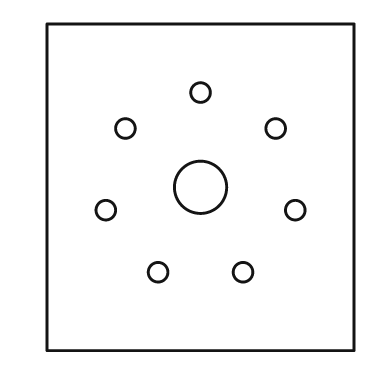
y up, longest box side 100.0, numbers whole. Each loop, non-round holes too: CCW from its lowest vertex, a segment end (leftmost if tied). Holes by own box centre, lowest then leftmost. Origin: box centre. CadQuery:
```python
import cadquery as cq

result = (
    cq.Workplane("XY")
    .moveTo(-47.0, -50.0)
    .lineTo(47.0, -50.0)
    .lineTo(47.0, 50.0)
    .lineTo(-47.0, 50.0)
    .close()
    .moveTo(-13.0, -26.0)
    .circle(3.0)
    .moveTo(13.0, -26.0)
    .circle(3.0)
    .moveTo(-29.0, -7.0)
    .circle(3.0)
    .moveTo(29.0, -7.0)
    .circle(3.0)
    .moveTo(0.0, 0.0)
    .circle(8.0)
    .moveTo(-23.0, 18.0)
    .circle(3.0)
    .moveTo(23.0, 18.0)
    .circle(3.0)
    .moveTo(0.0, 29.0)
    .circle(3.0)
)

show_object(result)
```